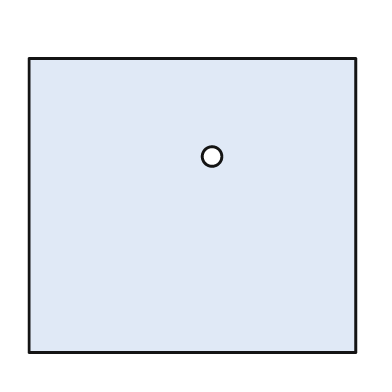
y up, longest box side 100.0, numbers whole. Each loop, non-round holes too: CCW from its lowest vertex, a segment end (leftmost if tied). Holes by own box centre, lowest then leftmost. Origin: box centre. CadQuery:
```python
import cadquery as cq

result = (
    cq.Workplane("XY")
    .moveTo(-50.0, -45.0)
    .lineTo(50.0, -45.0)
    .lineTo(50.0, 45.0)
    .lineTo(-50.0, 45.0)
    .close()
    .moveTo(6.0, 15.0)
    .circle(3.0)
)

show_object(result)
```